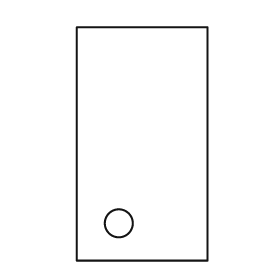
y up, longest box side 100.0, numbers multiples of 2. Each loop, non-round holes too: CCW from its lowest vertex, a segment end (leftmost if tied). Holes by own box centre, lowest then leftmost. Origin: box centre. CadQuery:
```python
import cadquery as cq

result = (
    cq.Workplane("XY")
    .moveTo(-28.0, -50.0)
    .lineTo(28.0, -50.0)
    .lineTo(28.0, 50.0)
    .lineTo(-28.0, 50.0)
    .close()
    .moveTo(-10.0, -34.0)
    .circle(6.0)
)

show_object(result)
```